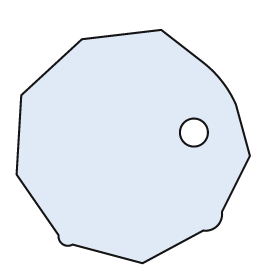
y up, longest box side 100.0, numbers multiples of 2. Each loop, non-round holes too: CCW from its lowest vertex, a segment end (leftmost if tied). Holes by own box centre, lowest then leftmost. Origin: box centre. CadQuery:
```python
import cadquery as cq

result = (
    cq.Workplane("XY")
    .moveTo(4.0, -50.0)
    .lineTo(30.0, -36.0)
    .threePointArc((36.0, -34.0), (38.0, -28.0))
    .lineTo(50.0, -4.0)
    .lineTo(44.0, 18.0)
    .threePointArc((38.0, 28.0), (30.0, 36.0))
    .lineTo(12.0, 50.0)
    .lineTo(-22.0, 46.0)
    .lineTo(-48.0, 22.0)
    .lineTo(-50.0, -12.0)
    .lineTo(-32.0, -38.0)
    .threePointArc((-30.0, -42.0), (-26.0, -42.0))
    .close()
    .moveTo(26.0, 6.0)
    .circle(6.0)
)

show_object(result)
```